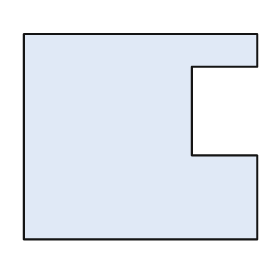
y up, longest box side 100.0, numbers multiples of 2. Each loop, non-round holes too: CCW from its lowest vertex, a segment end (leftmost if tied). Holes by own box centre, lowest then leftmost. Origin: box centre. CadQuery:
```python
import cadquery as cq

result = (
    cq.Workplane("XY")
    .moveTo(-50.0, -44.0)
    .lineTo(50.0, -44.0)
    .lineTo(50.0, -8.0)
    .lineTo(22.0, -8.0)
    .lineTo(22.0, 30.0)
    .lineTo(50.0, 30.0)
    .lineTo(50.0, 44.0)
    .lineTo(-50.0, 44.0)
    .close()
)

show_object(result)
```